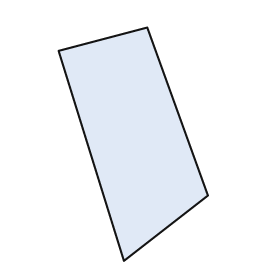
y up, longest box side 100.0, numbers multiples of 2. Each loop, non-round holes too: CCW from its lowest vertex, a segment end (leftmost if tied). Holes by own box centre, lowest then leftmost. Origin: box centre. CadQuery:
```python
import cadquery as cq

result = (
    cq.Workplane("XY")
    .moveTo(-4.0, -50.0)
    .lineTo(32.0, -22.0)
    .lineTo(6.0, 50.0)
    .lineTo(-32.0, 40.0)
    .close()
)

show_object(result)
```